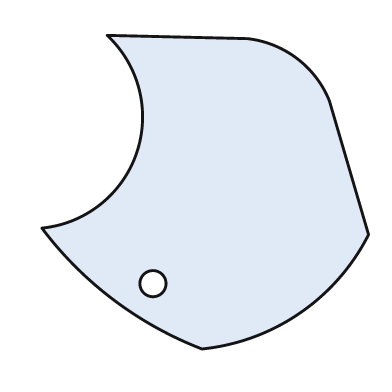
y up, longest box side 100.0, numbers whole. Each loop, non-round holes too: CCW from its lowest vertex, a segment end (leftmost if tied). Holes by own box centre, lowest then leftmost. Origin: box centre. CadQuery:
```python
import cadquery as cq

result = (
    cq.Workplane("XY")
    .moveTo(-1.0, -48.0)
    .threePointArc((29.0, -37.0), (50.0, -13.0))
    .lineTo(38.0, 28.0)
    .threePointArc((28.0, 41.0), (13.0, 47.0))
    .lineTo(-30.0, 48.0)
    .threePointArc((-21.0, 12.0), (-50.0, -11.0))
    .threePointArc((-28.0, -33.0), (-1.0, -48.0))
    .close()
    .moveTo(-16.0, -28.0)
    .circle(4.0)
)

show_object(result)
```